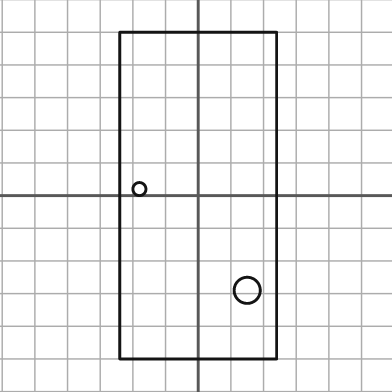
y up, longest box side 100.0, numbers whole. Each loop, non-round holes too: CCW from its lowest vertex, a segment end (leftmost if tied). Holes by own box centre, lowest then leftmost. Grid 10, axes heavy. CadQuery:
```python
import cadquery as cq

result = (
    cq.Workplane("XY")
    .moveTo(-24.0, -50.0)
    .lineTo(24.0, -50.0)
    .lineTo(24.0, 50.0)
    .lineTo(-24.0, 50.0)
    .close()
    .moveTo(15.0, -29.0)
    .circle(4.0)
    .moveTo(-18.0, 2.0)
    .circle(2.0)
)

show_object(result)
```